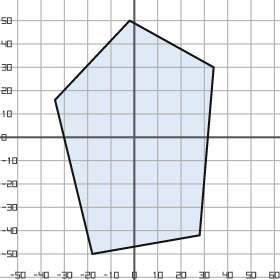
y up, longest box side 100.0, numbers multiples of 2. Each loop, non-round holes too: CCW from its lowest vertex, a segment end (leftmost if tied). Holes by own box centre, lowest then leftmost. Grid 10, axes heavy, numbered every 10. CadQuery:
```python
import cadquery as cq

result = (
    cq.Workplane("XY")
    .moveTo(-18.0, -50.0)
    .lineTo(28.0, -42.0)
    .lineTo(34.0, 30.0)
    .lineTo(-2.0, 50.0)
    .lineTo(-34.0, 16.0)
    .close()
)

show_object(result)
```